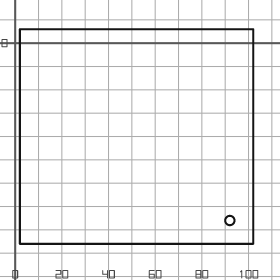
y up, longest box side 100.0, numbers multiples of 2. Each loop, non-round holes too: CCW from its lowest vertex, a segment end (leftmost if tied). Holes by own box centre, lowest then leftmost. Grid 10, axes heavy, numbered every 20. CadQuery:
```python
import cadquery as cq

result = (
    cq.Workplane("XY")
    .moveTo(2.0, -86.0)
    .lineTo(102.0, -86.0)
    .lineTo(102.0, 6.0)
    .lineTo(2.0, 6.0)
    .close()
    .moveTo(92.0, -76.0)
    .circle(2.0)
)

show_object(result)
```